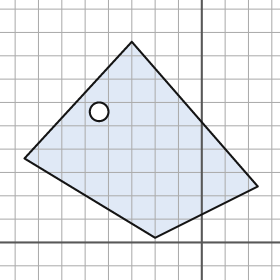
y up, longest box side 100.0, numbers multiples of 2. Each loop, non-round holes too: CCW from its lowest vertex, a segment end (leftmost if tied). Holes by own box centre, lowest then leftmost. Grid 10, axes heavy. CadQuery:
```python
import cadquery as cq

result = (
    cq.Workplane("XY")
    .moveTo(-20.0, 2.0)
    .lineTo(24.0, 24.0)
    .lineTo(-30.0, 86.0)
    .lineTo(-76.0, 36.0)
    .close()
    .moveTo(-44.0, 56.0)
    .circle(4.0)
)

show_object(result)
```